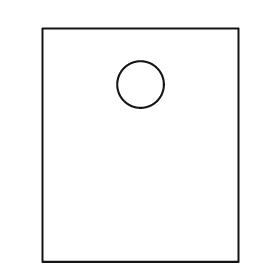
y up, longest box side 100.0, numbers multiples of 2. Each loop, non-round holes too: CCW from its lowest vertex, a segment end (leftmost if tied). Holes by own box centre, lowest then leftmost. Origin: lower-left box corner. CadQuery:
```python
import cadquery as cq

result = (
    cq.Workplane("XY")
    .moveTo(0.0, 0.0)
    .lineTo(84.0, 0.0)
    .lineTo(84.0, 100.0)
    .lineTo(0.0, 100.0)
    .close()
    .moveTo(42.0, 76.0)
    .circle(10.0)
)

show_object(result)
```